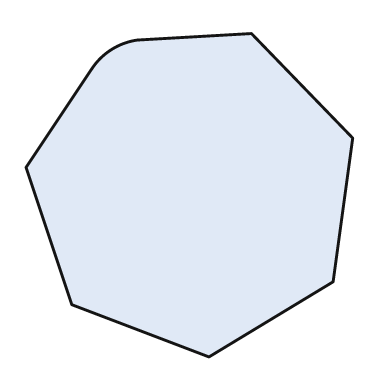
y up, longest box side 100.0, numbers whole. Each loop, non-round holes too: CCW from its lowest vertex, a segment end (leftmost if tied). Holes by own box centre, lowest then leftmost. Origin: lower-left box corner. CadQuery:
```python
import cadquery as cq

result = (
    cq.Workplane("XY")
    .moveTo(56.0, 0.0)
    .lineTo(94.0, 23.0)
    .lineTo(100.0, 67.0)
    .lineTo(69.0, 99.0)
    .lineTo(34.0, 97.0)
    .threePointArc((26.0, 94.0), (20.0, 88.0))
    .lineTo(0.0, 58.0)
    .lineTo(14.0, 16.0)
    .close()
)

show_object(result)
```